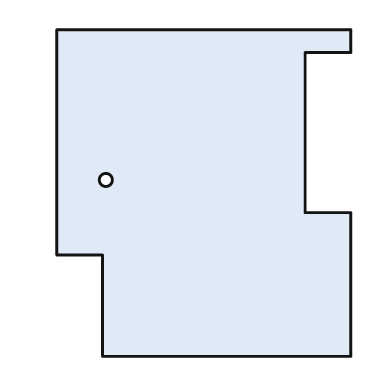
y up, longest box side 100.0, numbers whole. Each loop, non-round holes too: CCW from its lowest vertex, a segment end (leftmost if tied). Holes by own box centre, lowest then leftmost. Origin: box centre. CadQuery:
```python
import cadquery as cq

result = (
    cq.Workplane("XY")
    .moveTo(-31.0, -50.0)
    .lineTo(45.0, -50.0)
    .lineTo(45.0, -6.0)
    .lineTo(31.0, -6.0)
    .lineTo(31.0, 43.0)
    .lineTo(45.0, 43.0)
    .lineTo(45.0, 50.0)
    .lineTo(-45.0, 50.0)
    .lineTo(-45.0, -19.0)
    .lineTo(-31.0, -19.0)
    .close()
    .moveTo(-30.0, 4.0)
    .circle(2.0)
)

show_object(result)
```